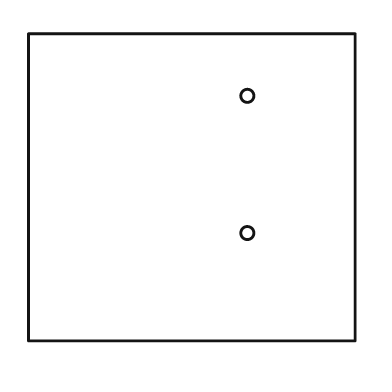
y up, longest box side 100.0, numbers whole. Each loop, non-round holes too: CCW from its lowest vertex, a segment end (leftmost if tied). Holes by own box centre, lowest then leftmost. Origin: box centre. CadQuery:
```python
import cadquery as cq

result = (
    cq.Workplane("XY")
    .moveTo(-50.0, -47.0)
    .lineTo(50.0, -47.0)
    .lineTo(50.0, 47.0)
    .lineTo(-50.0, 47.0)
    .close()
    .moveTo(17.0, -14.0)
    .circle(2.0)
    .moveTo(17.0, 28.0)
    .circle(2.0)
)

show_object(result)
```